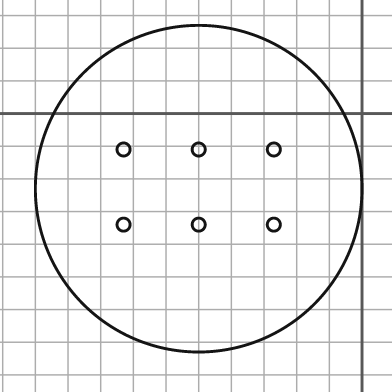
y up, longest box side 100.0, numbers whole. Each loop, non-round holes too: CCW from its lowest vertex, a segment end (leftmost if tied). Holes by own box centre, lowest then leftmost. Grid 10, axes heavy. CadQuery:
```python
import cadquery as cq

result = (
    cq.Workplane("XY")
    .moveTo(-50.0, -23.0)
    .circle(50.0)
    .moveTo(-73.0, -34.0)
    .circle(2.0)
    .moveTo(-50.0, -34.0)
    .circle(2.0)
    .moveTo(-27.0, -34.0)
    .circle(2.0)
    .moveTo(-73.0, -11.0)
    .circle(2.0)
    .moveTo(-50.0, -11.0)
    .circle(2.0)
    .moveTo(-27.0, -11.0)
    .circle(2.0)
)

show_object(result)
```